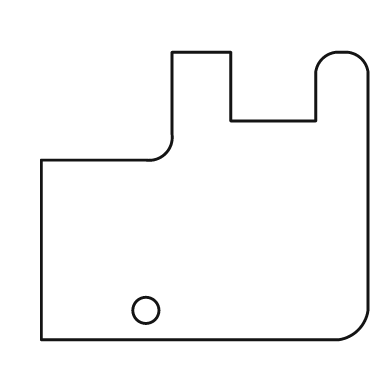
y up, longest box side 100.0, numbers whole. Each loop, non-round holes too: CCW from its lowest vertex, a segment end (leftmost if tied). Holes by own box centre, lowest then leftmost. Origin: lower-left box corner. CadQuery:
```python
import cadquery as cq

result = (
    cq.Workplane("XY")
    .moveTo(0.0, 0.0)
    .lineTo(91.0, 0.0)
    .threePointArc((97.0, 3.0), (100.0, 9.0))
    .lineTo(100.0, 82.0)
    .threePointArc((98.0, 86.0), (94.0, 88.0))
    .lineTo(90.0, 88.0)
    .threePointArc((86.0, 86.0), (84.0, 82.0))
    .lineTo(84.0, 67.0)
    .lineTo(58.0, 67.0)
    .lineTo(58.0, 88.0)
    .lineTo(40.0, 88.0)
    .lineTo(40.0, 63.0)
    .threePointArc((38.0, 57.0), (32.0, 55.0))
    .lineTo(0.0, 55.0)
    .close()
    .moveTo(32.0, 9.0)
    .circle(4.0)
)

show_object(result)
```